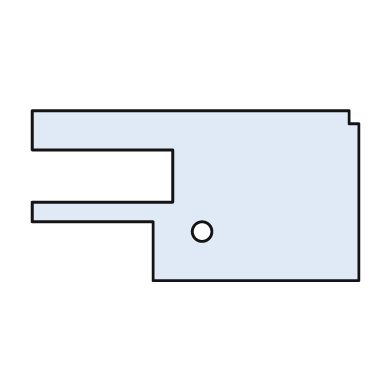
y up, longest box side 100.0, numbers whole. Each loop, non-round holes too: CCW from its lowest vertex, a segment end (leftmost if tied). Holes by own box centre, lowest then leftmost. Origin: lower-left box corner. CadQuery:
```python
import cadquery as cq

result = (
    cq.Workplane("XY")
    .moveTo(37.0, 0.0)
    .lineTo(100.0, 0.0)
    .lineTo(100.0, 48.0)
    .lineTo(97.0, 48.0)
    .lineTo(97.0, 52.0)
    .lineTo(0.0, 52.0)
    .lineTo(0.0, 40.0)
    .lineTo(43.0, 40.0)
    .lineTo(43.0, 24.0)
    .lineTo(0.0, 24.0)
    .lineTo(0.0, 18.0)
    .lineTo(37.0, 18.0)
    .close()
    .moveTo(52.0, 15.0)
    .circle(3.0)
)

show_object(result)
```